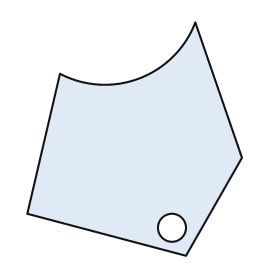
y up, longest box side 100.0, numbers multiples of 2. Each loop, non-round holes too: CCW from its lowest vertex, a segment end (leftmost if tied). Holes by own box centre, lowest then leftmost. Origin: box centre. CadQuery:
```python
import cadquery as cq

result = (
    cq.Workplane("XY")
    .moveTo(22.0, -50.0)
    .lineTo(46.0, -8.0)
    .lineTo(26.0, 50.0)
    .threePointArc((2.0, 26.0), (-32.0, 28.0))
    .lineTo(-46.0, -32.0)
    .close()
    .moveTo(16.0, -38.0)
    .circle(6.0)
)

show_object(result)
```